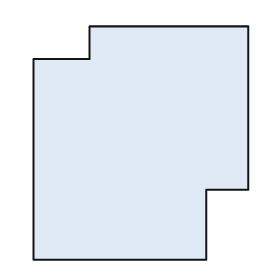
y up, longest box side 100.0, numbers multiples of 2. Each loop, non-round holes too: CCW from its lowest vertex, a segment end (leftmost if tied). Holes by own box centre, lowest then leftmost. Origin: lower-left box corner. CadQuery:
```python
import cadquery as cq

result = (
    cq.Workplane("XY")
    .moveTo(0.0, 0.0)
    .lineTo(74.0, 0.0)
    .lineTo(74.0, 30.0)
    .lineTo(92.0, 30.0)
    .lineTo(92.0, 100.0)
    .lineTo(24.0, 100.0)
    .lineTo(24.0, 86.0)
    .lineTo(0.0, 86.0)
    .close()
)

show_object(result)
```